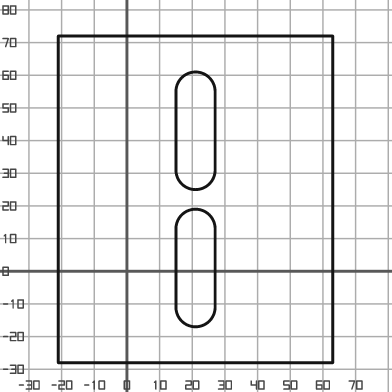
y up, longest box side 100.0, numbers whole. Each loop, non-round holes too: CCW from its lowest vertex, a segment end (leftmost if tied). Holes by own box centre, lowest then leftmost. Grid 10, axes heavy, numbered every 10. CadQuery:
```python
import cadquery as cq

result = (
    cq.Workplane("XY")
    .moveTo(-21.0, -28.0)
    .lineTo(63.0, -28.0)
    .lineTo(63.0, 72.0)
    .lineTo(-21.0, 72.0)
    .close()
    .moveTo(15.0, -11.0)
    .threePointArc((21.0, -17.0), (27.0, -11.0))
    .lineTo(27.0, 13.0)
    .threePointArc((21.0, 19.0), (15.0, 13.0))
    .close()
    .moveTo(15.0, 31.0)
    .threePointArc((21.0, 25.0), (27.0, 31.0))
    .lineTo(27.0, 55.0)
    .threePointArc((21.0, 61.0), (15.0, 55.0))
    .close()
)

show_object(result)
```